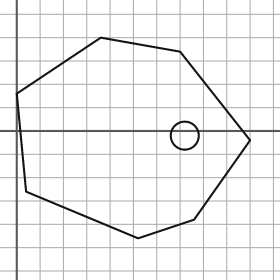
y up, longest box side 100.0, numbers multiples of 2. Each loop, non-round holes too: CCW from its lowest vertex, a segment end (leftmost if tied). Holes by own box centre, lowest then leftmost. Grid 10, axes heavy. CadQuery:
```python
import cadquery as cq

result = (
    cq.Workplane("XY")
    .moveTo(52.0, -46.0)
    .lineTo(76.0, -38.0)
    .lineTo(100.0, -4.0)
    .lineTo(70.0, 34.0)
    .lineTo(36.0, 40.0)
    .lineTo(0.0, 16.0)
    .lineTo(4.0, -26.0)
    .close()
    .moveTo(72.0, -2.0)
    .circle(6.0)
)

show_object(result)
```